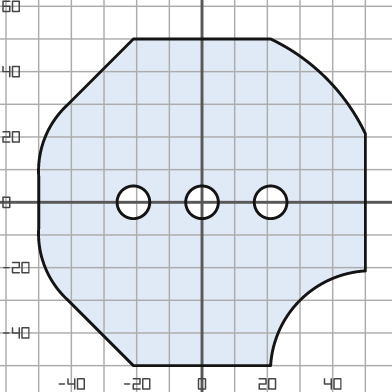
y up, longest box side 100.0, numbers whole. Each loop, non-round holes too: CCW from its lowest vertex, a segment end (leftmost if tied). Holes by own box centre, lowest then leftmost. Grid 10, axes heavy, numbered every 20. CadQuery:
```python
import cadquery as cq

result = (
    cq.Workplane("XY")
    .moveTo(-21.0, -50.0)
    .lineTo(21.0, -50.0)
    .threePointArc((30.0, -30.0), (50.0, -21.0))
    .lineTo(50.0, 21.0)
    .threePointArc((38.0, 38.0), (21.0, 50.0))
    .lineTo(-21.0, 50.0)
    .lineTo(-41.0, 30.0)
    .threePointArc((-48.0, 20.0), (-50.0, 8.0))
    .lineTo(-50.0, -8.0)
    .threePointArc((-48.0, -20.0), (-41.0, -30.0))
    .close()
    .moveTo(-21.0, 0.0)
    .circle(5.0)
    .moveTo(0.0, 0.0)
    .circle(5.0)
    .moveTo(21.0, 0.0)
    .circle(5.0)
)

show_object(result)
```